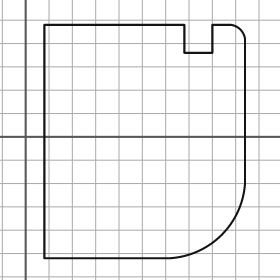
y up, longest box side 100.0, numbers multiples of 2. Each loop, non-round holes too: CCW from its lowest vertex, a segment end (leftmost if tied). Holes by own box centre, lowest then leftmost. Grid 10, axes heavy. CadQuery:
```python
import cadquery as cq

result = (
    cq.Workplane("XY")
    .moveTo(8.0, -52.0)
    .lineTo(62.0, -52.0)
    .threePointArc((84.0, -42.0), (94.0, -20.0))
    .lineTo(94.0, 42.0)
    .threePointArc((92.0, 46.0), (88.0, 48.0))
    .lineTo(80.0, 48.0)
    .lineTo(80.0, 36.0)
    .lineTo(68.0, 36.0)
    .lineTo(68.0, 48.0)
    .lineTo(8.0, 48.0)
    .close()
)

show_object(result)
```